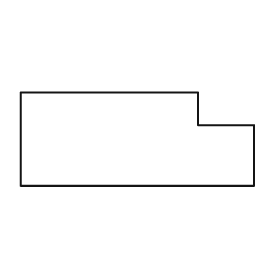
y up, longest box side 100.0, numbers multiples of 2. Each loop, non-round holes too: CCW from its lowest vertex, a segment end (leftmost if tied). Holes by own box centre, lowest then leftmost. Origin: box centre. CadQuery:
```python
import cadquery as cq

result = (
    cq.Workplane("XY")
    .moveTo(-50.0, -20.0)
    .lineTo(50.0, -20.0)
    .lineTo(50.0, 6.0)
    .lineTo(26.0, 6.0)
    .lineTo(26.0, 20.0)
    .lineTo(-50.0, 20.0)
    .close()
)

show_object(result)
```